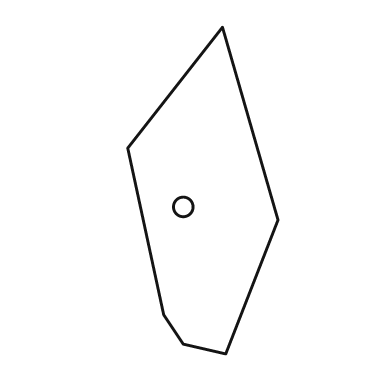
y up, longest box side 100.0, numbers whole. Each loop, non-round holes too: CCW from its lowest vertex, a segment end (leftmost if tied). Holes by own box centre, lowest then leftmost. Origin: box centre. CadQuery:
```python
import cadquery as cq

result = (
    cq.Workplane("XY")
    .moveTo(7.0, -50.0)
    .lineTo(23.0, -9.0)
    .lineTo(6.0, 50.0)
    .lineTo(-23.0, 13.0)
    .lineTo(-12.0, -38.0)
    .lineTo(-6.0, -47.0)
    .close()
    .moveTo(-6.0, -5.0)
    .circle(3.0)
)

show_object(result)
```